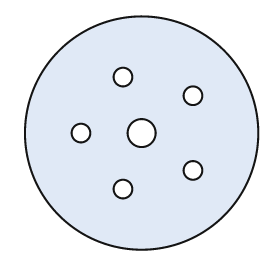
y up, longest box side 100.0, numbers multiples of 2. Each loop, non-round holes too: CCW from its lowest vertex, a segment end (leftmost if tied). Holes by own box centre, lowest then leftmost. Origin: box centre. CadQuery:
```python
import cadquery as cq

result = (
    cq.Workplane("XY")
    .moveTo(0.0, 0.0)
    .circle(50.0)
    .moveTo(-8.0, -24.0)
    .circle(4.0)
    .moveTo(22.0, -16.0)
    .circle(4.0)
    .moveTo(-26.0, 0.0)
    .circle(4.0)
    .moveTo(0.0, 0.0)
    .circle(6.0)
    .moveTo(22.0, 16.0)
    .circle(4.0)
    .moveTo(-8.0, 24.0)
    .circle(4.0)
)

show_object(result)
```